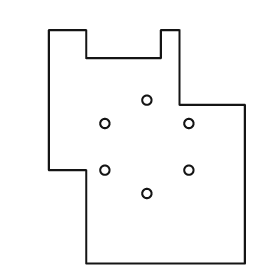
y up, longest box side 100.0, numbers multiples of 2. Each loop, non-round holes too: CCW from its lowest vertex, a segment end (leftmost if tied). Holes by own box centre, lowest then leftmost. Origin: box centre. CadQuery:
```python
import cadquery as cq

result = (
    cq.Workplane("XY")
    .moveTo(-26.0, -50.0)
    .lineTo(42.0, -50.0)
    .lineTo(42.0, 18.0)
    .lineTo(14.0, 18.0)
    .lineTo(14.0, 50.0)
    .lineTo(6.0, 50.0)
    .lineTo(6.0, 38.0)
    .lineTo(-26.0, 38.0)
    .lineTo(-26.0, 50.0)
    .lineTo(-42.0, 50.0)
    .lineTo(-42.0, -10.0)
    .lineTo(-26.0, -10.0)
    .close()
    .moveTo(0.0, -20.0)
    .circle(2.0)
    .moveTo(-18.0, -10.0)
    .circle(2.0)
    .moveTo(18.0, -10.0)
    .circle(2.0)
    .moveTo(-18.0, 10.0)
    .circle(2.0)
    .moveTo(18.0, 10.0)
    .circle(2.0)
    .moveTo(0.0, 20.0)
    .circle(2.0)
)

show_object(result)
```